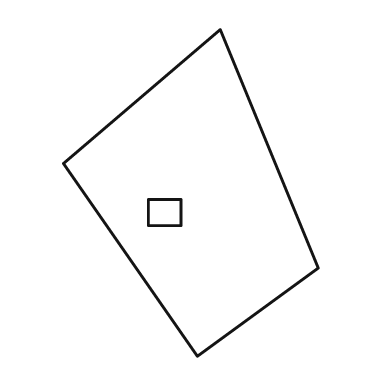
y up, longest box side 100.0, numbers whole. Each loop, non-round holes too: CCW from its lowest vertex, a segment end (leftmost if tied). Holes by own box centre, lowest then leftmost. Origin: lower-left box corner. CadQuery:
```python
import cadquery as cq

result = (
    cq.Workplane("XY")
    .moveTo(41.0, 0.0)
    .lineTo(78.0, 27.0)
    .lineTo(48.0, 100.0)
    .lineTo(0.0, 59.0)
    .close()
    .moveTo(26.0, 40.0)
    .lineTo(36.0, 40.0)
    .lineTo(36.0, 48.0)
    .lineTo(26.0, 48.0)
    .close()
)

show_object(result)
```